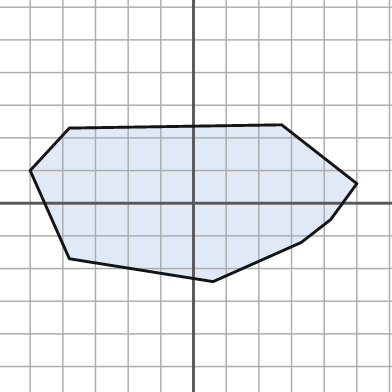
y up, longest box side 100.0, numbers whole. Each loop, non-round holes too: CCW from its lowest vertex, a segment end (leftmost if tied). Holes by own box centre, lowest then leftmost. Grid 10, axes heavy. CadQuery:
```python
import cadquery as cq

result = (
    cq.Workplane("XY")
    .moveTo(6.0, -24.0)
    .lineTo(33.0, -12.0)
    .lineTo(42.0, -5.0)
    .lineTo(50.0, 6.0)
    .lineTo(27.0, 24.0)
    .lineTo(-38.0, 23.0)
    .lineTo(-50.0, 10.0)
    .lineTo(-38.0, -17.0)
    .close()
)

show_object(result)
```